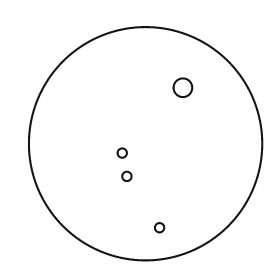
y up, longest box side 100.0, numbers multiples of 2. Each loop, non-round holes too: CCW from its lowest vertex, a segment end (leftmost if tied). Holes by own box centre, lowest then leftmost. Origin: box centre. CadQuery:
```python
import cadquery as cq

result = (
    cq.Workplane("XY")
    .moveTo(0.0, 0.0)
    .circle(50.0)
    .moveTo(6.0, -36.0)
    .circle(2.0)
    .moveTo(-8.0, -14.0)
    .circle(2.0)
    .moveTo(-10.0, -4.0)
    .circle(2.0)
    .moveTo(16.0, 24.0)
    .circle(4.0)
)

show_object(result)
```